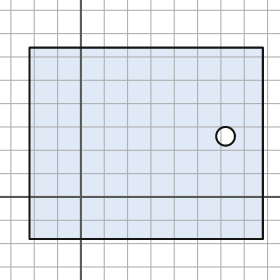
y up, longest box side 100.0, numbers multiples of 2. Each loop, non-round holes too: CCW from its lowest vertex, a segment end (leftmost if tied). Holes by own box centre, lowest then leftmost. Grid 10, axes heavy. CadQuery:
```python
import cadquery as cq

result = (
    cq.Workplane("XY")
    .moveTo(-22.0, -18.0)
    .lineTo(78.0, -18.0)
    .lineTo(78.0, 64.0)
    .lineTo(-22.0, 64.0)
    .close()
    .moveTo(62.0, 26.0)
    .circle(4.0)
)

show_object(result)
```